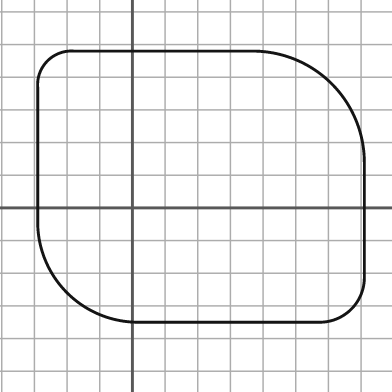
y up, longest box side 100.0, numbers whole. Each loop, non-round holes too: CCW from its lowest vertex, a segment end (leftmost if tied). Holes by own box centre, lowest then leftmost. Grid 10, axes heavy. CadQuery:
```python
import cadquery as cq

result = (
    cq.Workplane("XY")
    .moveTo(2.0, -35.0)
    .lineTo(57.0, -35.0)
    .threePointArc((67.0, -31.0), (71.0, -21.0))
    .lineTo(71.0, 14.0)
    .threePointArc((61.0, 38.0), (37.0, 48.0))
    .lineTo(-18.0, 48.0)
    .threePointArc((-26.0, 45.0), (-29.0, 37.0))
    .lineTo(-29.0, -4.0)
    .threePointArc((-20.0, -26.0), (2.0, -35.0))
    .close()
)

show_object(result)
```